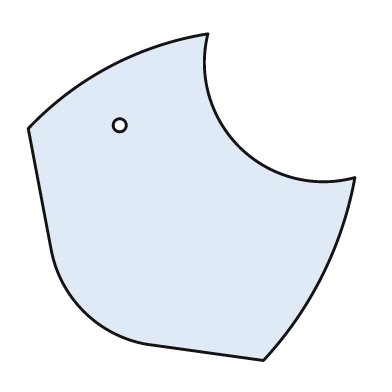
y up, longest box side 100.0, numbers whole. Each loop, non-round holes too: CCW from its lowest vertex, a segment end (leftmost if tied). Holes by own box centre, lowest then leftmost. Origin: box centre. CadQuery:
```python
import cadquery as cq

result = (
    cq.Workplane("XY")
    .moveTo(22.0, -50.0)
    .threePointArc((40.0, -24.0), (50.0, 6.0))
    .threePointArc((15.0, 15.0), (5.0, 50.0))
    .threePointArc((-25.0, 40.0), (-50.0, 21.0))
    .lineTo(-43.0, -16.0)
    .threePointArc((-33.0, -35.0), (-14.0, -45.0))
    .close()
    .moveTo(-22.0, 22.0)
    .circle(2.0)
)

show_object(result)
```